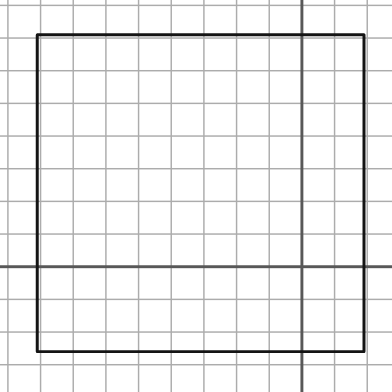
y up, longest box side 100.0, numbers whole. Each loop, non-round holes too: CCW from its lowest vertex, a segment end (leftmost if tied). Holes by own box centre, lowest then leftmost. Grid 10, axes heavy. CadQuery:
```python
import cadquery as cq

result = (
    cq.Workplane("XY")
    .moveTo(-81.0, -26.0)
    .lineTo(19.0, -26.0)
    .lineTo(19.0, 71.0)
    .lineTo(-81.0, 71.0)
    .close()
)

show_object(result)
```